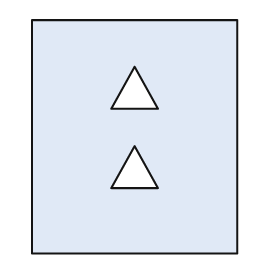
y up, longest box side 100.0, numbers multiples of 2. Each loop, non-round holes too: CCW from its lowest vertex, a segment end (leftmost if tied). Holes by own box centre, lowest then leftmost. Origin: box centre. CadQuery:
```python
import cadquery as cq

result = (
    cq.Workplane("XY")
    .moveTo(-44.0, -50.0)
    .lineTo(44.0, -50.0)
    .lineTo(44.0, 50.0)
    .lineTo(-44.0, 50.0)
    .close()
    .moveTo(-10.0, -22.0)
    .lineTo(10.0, -22.0)
    .lineTo(0.0, -4.0)
    .close()
    .moveTo(-10.0, 12.0)
    .lineTo(10.0, 12.0)
    .lineTo(0.0, 30.0)
    .close()
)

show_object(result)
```